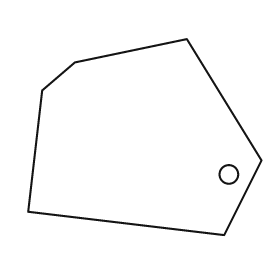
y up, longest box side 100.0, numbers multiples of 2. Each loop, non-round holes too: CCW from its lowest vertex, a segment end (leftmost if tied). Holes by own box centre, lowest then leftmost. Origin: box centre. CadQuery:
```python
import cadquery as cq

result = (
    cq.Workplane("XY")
    .moveTo(34.0, -42.0)
    .lineTo(50.0, -10.0)
    .lineTo(18.0, 42.0)
    .lineTo(-30.0, 32.0)
    .lineTo(-44.0, 20.0)
    .lineTo(-50.0, -32.0)
    .close()
    .moveTo(36.0, -16.0)
    .circle(4.0)
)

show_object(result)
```